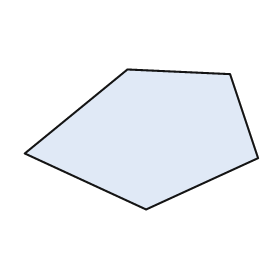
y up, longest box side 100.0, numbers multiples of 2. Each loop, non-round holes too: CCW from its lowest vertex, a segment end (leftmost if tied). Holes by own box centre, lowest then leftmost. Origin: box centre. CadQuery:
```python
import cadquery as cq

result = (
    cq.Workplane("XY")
    .moveTo(2.0, -30.0)
    .lineTo(50.0, -8.0)
    .lineTo(38.0, 28.0)
    .lineTo(-6.0, 30.0)
    .lineTo(-50.0, -6.0)
    .close()
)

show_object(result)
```